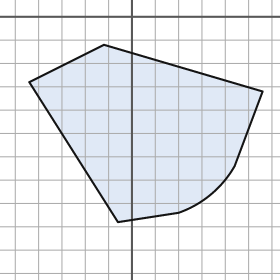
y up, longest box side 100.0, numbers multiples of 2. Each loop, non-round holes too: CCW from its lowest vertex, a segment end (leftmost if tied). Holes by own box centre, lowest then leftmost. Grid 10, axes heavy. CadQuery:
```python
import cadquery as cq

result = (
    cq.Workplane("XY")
    .moveTo(-6.0, -88.0)
    .lineTo(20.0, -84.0)
    .threePointArc((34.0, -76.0), (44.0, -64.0))
    .lineTo(56.0, -32.0)
    .lineTo(-12.0, -12.0)
    .lineTo(-44.0, -28.0)
    .close()
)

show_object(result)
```